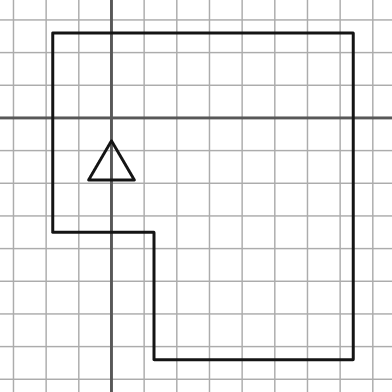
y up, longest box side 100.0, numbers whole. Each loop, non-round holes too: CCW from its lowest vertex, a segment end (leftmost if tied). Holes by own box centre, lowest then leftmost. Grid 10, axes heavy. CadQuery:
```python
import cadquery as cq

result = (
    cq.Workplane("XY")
    .moveTo(13.0, -74.0)
    .lineTo(74.0, -74.0)
    .lineTo(74.0, 26.0)
    .lineTo(-18.0, 26.0)
    .lineTo(-18.0, -35.0)
    .lineTo(13.0, -35.0)
    .close()
    .moveTo(-7.0, -19.0)
    .lineTo(7.0, -19.0)
    .lineTo(0.0, -7.0)
    .close()
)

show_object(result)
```